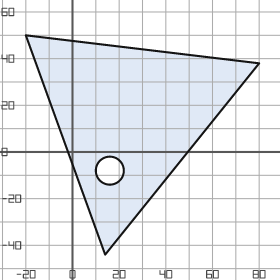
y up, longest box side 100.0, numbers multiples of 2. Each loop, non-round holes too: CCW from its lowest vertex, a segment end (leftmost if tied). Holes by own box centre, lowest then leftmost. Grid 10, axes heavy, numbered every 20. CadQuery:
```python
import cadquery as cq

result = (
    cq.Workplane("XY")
    .moveTo(14.0, -44.0)
    .lineTo(80.0, 38.0)
    .lineTo(-20.0, 50.0)
    .close()
    .moveTo(16.0, -8.0)
    .circle(6.0)
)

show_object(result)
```